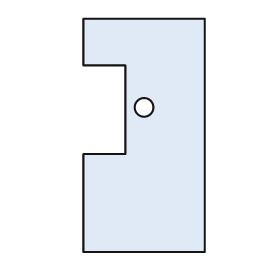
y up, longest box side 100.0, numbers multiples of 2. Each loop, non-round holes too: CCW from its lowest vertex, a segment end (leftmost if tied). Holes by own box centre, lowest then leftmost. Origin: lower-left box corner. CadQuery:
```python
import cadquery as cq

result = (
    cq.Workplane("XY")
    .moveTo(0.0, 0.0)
    .lineTo(52.0, 0.0)
    .lineTo(52.0, 100.0)
    .lineTo(0.0, 100.0)
    .lineTo(0.0, 80.0)
    .lineTo(18.0, 80.0)
    .lineTo(18.0, 42.0)
    .lineTo(0.0, 42.0)
    .close()
    .moveTo(26.0, 62.0)
    .circle(4.0)
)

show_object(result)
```